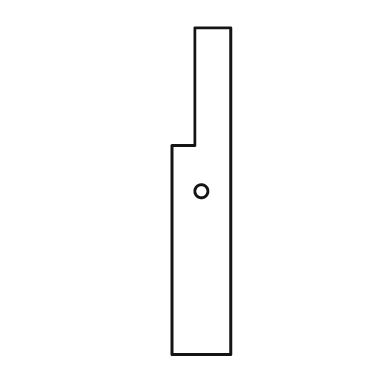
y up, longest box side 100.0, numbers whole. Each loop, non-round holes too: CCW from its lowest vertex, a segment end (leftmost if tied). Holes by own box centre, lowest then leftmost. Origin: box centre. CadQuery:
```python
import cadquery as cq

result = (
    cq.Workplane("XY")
    .moveTo(-9.0, -50.0)
    .lineTo(9.0, -50.0)
    .lineTo(9.0, 50.0)
    .lineTo(-2.0, 50.0)
    .lineTo(-2.0, 14.0)
    .lineTo(-9.0, 14.0)
    .close()
    .moveTo(0.0, 0.0)
    .circle(2.0)
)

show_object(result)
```